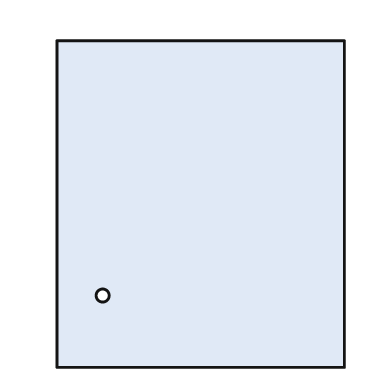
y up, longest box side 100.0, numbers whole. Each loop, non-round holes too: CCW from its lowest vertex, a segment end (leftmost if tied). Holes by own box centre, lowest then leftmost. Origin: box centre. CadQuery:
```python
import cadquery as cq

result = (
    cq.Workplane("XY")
    .moveTo(-44.0, -50.0)
    .lineTo(44.0, -50.0)
    .lineTo(44.0, 50.0)
    .lineTo(-44.0, 50.0)
    .close()
    .moveTo(-30.0, -28.0)
    .circle(2.0)
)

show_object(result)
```